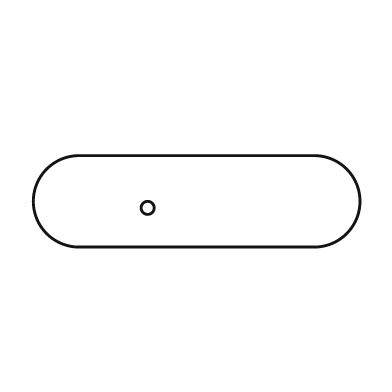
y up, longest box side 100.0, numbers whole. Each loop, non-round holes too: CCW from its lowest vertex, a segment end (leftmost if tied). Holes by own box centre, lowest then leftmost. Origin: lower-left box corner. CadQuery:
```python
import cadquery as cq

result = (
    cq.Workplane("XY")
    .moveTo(14.0, 0.0)
    .lineTo(86.0, 0.0)
    .threePointArc((100.0, 14.0), (86.0, 28.0))
    .lineTo(14.0, 28.0)
    .threePointArc((0.0, 14.0), (14.0, 0.0))
    .close()
    .moveTo(35.0, 12.0)
    .circle(2.0)
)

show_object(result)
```